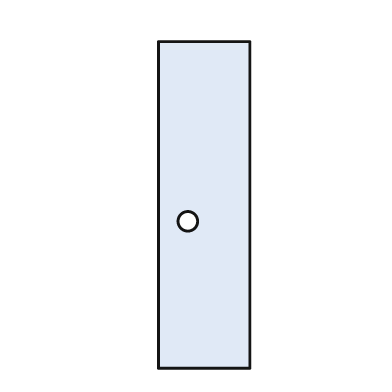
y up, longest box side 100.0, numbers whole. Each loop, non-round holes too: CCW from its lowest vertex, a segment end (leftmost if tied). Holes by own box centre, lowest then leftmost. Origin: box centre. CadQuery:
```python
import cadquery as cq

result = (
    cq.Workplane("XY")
    .moveTo(-14.0, -50.0)
    .lineTo(14.0, -50.0)
    .lineTo(14.0, 50.0)
    .lineTo(-14.0, 50.0)
    .close()
    .moveTo(-5.0, -5.0)
    .circle(3.0)
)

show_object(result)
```